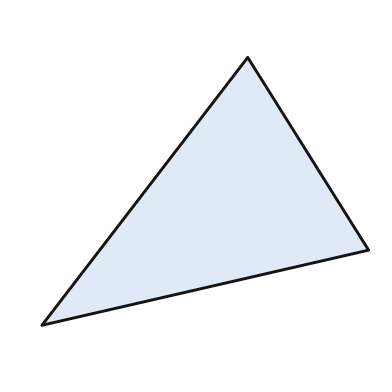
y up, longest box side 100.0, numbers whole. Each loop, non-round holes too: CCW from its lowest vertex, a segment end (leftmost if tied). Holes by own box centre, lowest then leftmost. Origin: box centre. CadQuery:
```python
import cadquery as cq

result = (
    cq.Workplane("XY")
    .moveTo(-50.0, -41.0)
    .lineTo(50.0, -18.0)
    .lineTo(13.0, 41.0)
    .close()
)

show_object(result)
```